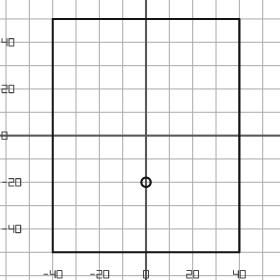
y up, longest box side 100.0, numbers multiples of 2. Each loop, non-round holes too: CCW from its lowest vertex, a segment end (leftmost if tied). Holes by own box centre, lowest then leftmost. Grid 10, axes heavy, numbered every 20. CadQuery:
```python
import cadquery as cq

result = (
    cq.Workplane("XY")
    .moveTo(-40.0, -50.0)
    .lineTo(40.0, -50.0)
    .lineTo(40.0, 50.0)
    .lineTo(-40.0, 50.0)
    .close()
    .moveTo(0.0, -20.0)
    .circle(2.0)
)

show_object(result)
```